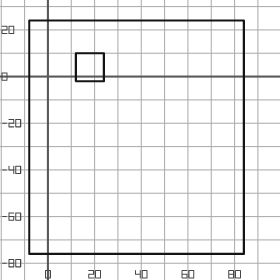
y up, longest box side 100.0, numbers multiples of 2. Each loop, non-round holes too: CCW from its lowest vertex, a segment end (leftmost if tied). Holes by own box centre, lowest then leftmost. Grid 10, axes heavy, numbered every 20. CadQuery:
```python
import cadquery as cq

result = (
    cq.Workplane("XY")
    .moveTo(-8.0, -76.0)
    .lineTo(84.0, -76.0)
    .lineTo(84.0, 24.0)
    .lineTo(-8.0, 24.0)
    .close()
    .moveTo(12.0, -2.0)
    .lineTo(24.0, -2.0)
    .lineTo(24.0, 10.0)
    .lineTo(12.0, 10.0)
    .close()
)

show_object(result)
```